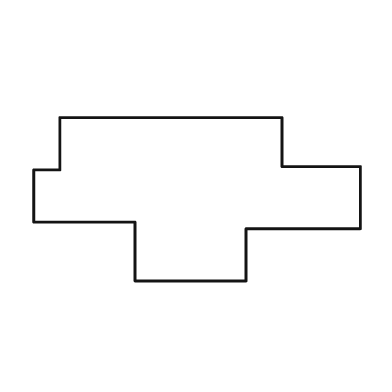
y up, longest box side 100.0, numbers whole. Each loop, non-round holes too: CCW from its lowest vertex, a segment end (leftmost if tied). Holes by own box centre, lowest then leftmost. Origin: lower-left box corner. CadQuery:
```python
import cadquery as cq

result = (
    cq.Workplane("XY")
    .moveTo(31.0, 0.0)
    .lineTo(65.0, 0.0)
    .lineTo(65.0, 16.0)
    .lineTo(100.0, 16.0)
    .lineTo(100.0, 35.0)
    .lineTo(76.0, 35.0)
    .lineTo(76.0, 50.0)
    .lineTo(8.0, 50.0)
    .lineTo(8.0, 34.0)
    .lineTo(0.0, 34.0)
    .lineTo(0.0, 18.0)
    .lineTo(31.0, 18.0)
    .close()
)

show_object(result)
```